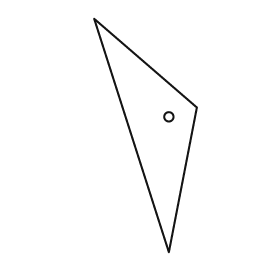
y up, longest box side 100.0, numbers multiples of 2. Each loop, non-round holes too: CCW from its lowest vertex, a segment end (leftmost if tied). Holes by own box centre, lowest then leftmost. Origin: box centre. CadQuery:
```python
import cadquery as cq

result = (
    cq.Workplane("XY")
    .moveTo(10.0, -50.0)
    .lineTo(22.0, 12.0)
    .lineTo(-22.0, 50.0)
    .close()
    .moveTo(10.0, 8.0)
    .circle(2.0)
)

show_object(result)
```